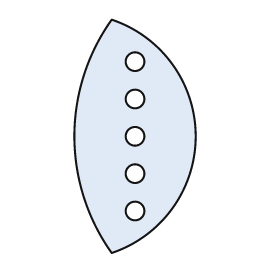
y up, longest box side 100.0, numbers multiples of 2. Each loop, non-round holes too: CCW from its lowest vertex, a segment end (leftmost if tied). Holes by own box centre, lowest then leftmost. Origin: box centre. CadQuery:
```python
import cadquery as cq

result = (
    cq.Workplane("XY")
    .moveTo(-10.0, -50.0)
    .threePointArc((26.0, 0.0), (-10.0, 50.0))
    .threePointArc((-26.0, 0.0), (-10.0, -50.0))
    .close()
    .moveTo(0.0, -32.0)
    .circle(4.0)
    .moveTo(0.0, -16.0)
    .circle(4.0)
    .moveTo(0.0, 0.0)
    .circle(4.0)
    .moveTo(0.0, 16.0)
    .circle(4.0)
    .moveTo(0.0, 32.0)
    .circle(4.0)
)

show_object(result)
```